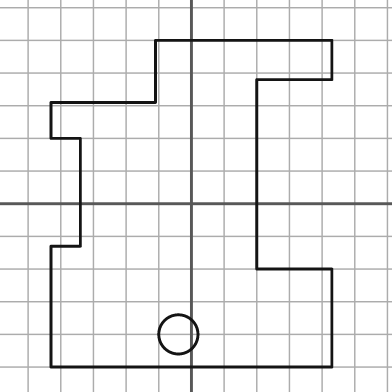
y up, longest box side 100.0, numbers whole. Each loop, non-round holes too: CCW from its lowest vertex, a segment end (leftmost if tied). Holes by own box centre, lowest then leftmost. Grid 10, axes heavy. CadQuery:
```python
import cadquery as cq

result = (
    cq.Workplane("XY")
    .moveTo(-43.0, -50.0)
    .lineTo(43.0, -50.0)
    .lineTo(43.0, -20.0)
    .lineTo(20.0, -20.0)
    .lineTo(20.0, 38.0)
    .lineTo(43.0, 38.0)
    .lineTo(43.0, 50.0)
    .lineTo(-11.0, 50.0)
    .lineTo(-11.0, 31.0)
    .lineTo(-43.0, 31.0)
    .lineTo(-43.0, 20.0)
    .lineTo(-34.0, 20.0)
    .lineTo(-34.0, -13.0)
    .lineTo(-43.0, -13.0)
    .close()
    .moveTo(-4.0, -40.0)
    .circle(6.0)
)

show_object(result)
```